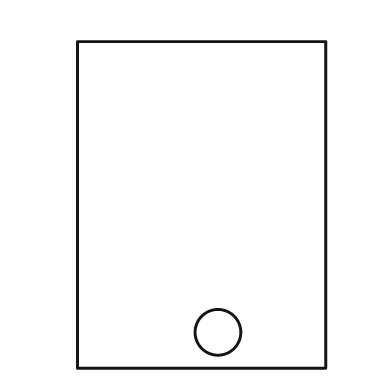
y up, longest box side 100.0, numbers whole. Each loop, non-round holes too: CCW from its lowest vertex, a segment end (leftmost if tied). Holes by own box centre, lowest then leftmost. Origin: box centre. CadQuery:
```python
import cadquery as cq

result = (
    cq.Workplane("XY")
    .moveTo(-38.0, -50.0)
    .lineTo(38.0, -50.0)
    .lineTo(38.0, 50.0)
    .lineTo(-38.0, 50.0)
    .close()
    .moveTo(5.0, -39.0)
    .circle(7.0)
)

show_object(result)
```